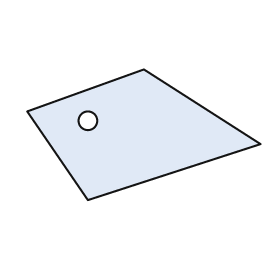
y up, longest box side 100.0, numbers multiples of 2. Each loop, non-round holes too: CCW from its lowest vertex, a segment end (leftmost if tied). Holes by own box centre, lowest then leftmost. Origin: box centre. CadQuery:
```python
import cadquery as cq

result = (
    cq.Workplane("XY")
    .moveTo(-24.0, -28.0)
    .lineTo(50.0, -4.0)
    .lineTo(0.0, 28.0)
    .lineTo(-50.0, 10.0)
    .close()
    .moveTo(-24.0, 6.0)
    .circle(4.0)
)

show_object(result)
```